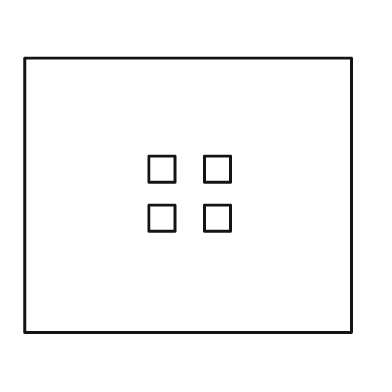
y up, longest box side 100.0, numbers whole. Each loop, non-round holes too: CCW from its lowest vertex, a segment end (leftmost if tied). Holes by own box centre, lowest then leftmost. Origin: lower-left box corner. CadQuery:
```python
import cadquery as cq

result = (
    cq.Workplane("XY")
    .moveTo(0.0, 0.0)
    .lineTo(100.0, 0.0)
    .lineTo(100.0, 84.0)
    .lineTo(0.0, 84.0)
    .close()
    .moveTo(38.0, 31.0)
    .lineTo(46.0, 31.0)
    .lineTo(46.0, 39.0)
    .lineTo(38.0, 39.0)
    .close()
    .moveTo(55.0, 31.0)
    .lineTo(63.0, 31.0)
    .lineTo(63.0, 39.0)
    .lineTo(55.0, 39.0)
    .close()
    .moveTo(38.0, 46.0)
    .lineTo(46.0, 46.0)
    .lineTo(46.0, 54.0)
    .lineTo(38.0, 54.0)
    .close()
    .moveTo(55.0, 46.0)
    .lineTo(63.0, 46.0)
    .lineTo(63.0, 54.0)
    .lineTo(55.0, 54.0)
    .close()
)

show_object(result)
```